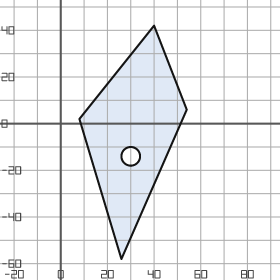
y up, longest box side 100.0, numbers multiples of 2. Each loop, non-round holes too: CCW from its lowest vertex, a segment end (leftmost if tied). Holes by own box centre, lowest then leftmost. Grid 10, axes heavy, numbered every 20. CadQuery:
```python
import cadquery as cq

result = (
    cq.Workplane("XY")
    .moveTo(26.0, -58.0)
    .lineTo(54.0, 6.0)
    .lineTo(40.0, 42.0)
    .lineTo(8.0, 2.0)
    .close()
    .moveTo(30.0, -14.0)
    .circle(4.0)
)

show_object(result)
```